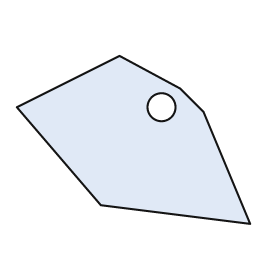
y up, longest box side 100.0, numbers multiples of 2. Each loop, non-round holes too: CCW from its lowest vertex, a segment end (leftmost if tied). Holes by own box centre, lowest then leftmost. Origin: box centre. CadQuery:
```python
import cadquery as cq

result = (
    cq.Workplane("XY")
    .moveTo(50.0, -36.0)
    .lineTo(30.0, 12.0)
    .lineTo(20.0, 22.0)
    .lineTo(-6.0, 36.0)
    .lineTo(-50.0, 14.0)
    .lineTo(-14.0, -28.0)
    .close()
    .moveTo(12.0, 14.0)
    .circle(6.0)
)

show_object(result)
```